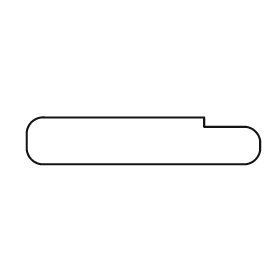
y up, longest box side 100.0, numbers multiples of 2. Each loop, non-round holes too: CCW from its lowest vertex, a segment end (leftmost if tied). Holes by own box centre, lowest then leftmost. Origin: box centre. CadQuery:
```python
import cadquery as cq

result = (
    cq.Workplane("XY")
    .moveTo(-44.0, -10.0)
    .lineTo(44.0, -10.0)
    .threePointArc((48.0, -8.0), (50.0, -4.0))
    .lineTo(50.0, 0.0)
    .threePointArc((48.0, 4.0), (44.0, 6.0))
    .lineTo(26.0, 6.0)
    .lineTo(26.0, 10.0)
    .lineTo(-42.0, 10.0)
    .threePointArc((-48.0, 8.0), (-50.0, 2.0))
    .lineTo(-50.0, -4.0)
    .threePointArc((-48.0, -8.0), (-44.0, -10.0))
    .close()
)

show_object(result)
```